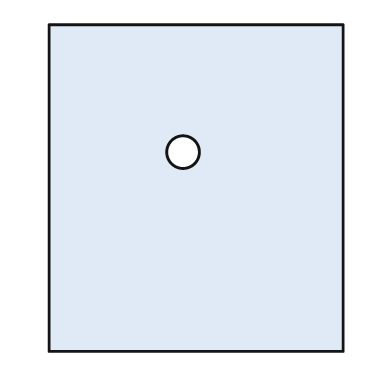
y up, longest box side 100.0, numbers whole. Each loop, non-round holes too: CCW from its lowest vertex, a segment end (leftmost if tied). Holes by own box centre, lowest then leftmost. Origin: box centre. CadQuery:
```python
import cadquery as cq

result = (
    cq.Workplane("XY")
    .moveTo(-45.0, -50.0)
    .lineTo(45.0, -50.0)
    .lineTo(45.0, 50.0)
    .lineTo(-45.0, 50.0)
    .close()
    .moveTo(-4.0, 11.0)
    .circle(5.0)
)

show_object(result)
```